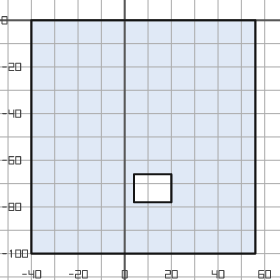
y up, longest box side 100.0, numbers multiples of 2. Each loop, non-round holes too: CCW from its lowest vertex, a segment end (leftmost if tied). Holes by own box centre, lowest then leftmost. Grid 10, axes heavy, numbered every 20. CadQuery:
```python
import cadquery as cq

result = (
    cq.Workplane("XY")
    .moveTo(-40.0, -100.0)
    .lineTo(56.0, -100.0)
    .lineTo(56.0, 0.0)
    .lineTo(-40.0, 0.0)
    .close()
    .moveTo(4.0, -78.0)
    .lineTo(20.0, -78.0)
    .lineTo(20.0, -66.0)
    .lineTo(4.0, -66.0)
    .close()
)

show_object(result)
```